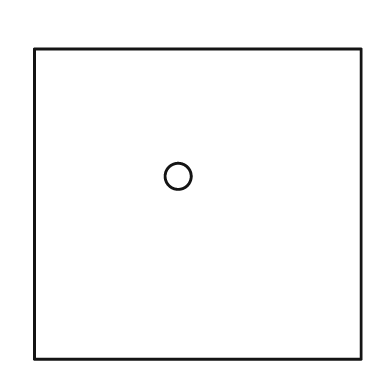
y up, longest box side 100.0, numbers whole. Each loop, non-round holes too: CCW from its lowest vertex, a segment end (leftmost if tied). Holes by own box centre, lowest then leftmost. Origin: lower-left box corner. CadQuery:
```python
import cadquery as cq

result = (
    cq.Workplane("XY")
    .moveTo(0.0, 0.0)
    .lineTo(100.0, 0.0)
    .lineTo(100.0, 95.0)
    .lineTo(0.0, 95.0)
    .close()
    .moveTo(44.0, 56.0)
    .circle(4.0)
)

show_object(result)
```